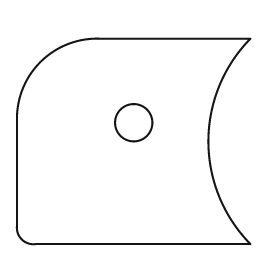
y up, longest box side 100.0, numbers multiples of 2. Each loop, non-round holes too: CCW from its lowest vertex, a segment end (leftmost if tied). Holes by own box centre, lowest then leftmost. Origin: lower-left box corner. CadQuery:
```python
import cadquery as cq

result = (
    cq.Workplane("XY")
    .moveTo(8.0, 0.0)
    .lineTo(100.0, 0.0)
    .threePointArc((82.0, 44.0), (100.0, 88.0))
    .lineTo(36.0, 88.0)
    .threePointArc((10.0, 78.0), (0.0, 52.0))
    .lineTo(0.0, 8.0)
    .threePointArc((2.0, 2.0), (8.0, 0.0))
    .close()
    .moveTo(50.0, 52.0)
    .circle(8.0)
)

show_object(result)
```